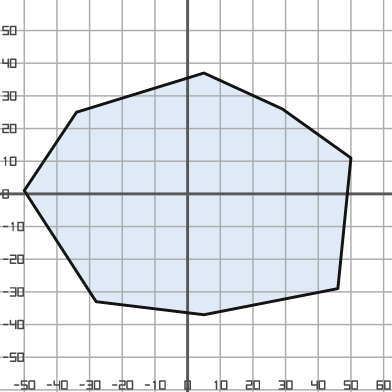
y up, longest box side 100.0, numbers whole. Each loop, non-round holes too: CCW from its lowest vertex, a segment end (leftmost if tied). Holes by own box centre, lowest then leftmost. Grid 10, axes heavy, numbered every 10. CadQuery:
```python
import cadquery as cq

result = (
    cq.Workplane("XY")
    .moveTo(5.0, -37.0)
    .lineTo(46.0, -29.0)
    .lineTo(50.0, 11.0)
    .lineTo(29.0, 26.0)
    .lineTo(5.0, 37.0)
    .lineTo(-34.0, 25.0)
    .lineTo(-50.0, 1.0)
    .lineTo(-28.0, -33.0)
    .close()
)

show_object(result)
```